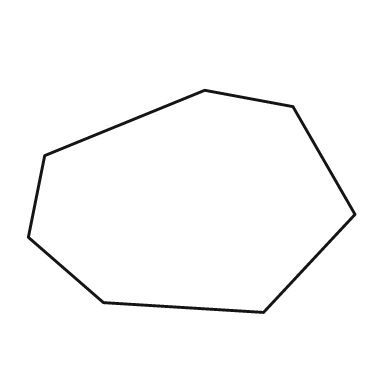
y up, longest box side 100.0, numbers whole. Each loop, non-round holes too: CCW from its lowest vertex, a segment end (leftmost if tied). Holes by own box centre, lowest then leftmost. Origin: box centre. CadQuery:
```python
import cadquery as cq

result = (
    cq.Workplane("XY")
    .moveTo(22.0, -34.0)
    .lineTo(50.0, -4.0)
    .lineTo(31.0, 29.0)
    .lineTo(4.0, 34.0)
    .lineTo(-45.0, 14.0)
    .lineTo(-50.0, -11.0)
    .lineTo(-27.0, -31.0)
    .close()
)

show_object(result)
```